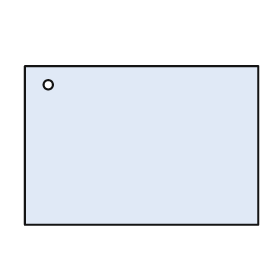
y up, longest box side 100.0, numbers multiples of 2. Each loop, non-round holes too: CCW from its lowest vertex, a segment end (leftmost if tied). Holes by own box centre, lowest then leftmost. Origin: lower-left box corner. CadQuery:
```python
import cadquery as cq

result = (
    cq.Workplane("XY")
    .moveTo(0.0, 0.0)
    .lineTo(100.0, 0.0)
    .lineTo(100.0, 68.0)
    .lineTo(0.0, 68.0)
    .close()
    .moveTo(10.0, 60.0)
    .circle(2.0)
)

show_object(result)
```